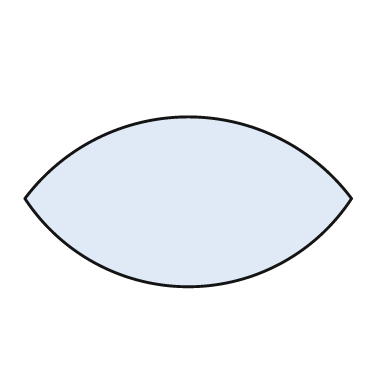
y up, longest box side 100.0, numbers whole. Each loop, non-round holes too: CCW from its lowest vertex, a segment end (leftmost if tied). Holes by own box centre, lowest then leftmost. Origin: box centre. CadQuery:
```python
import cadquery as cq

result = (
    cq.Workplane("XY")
    .moveTo(-50.0, 1.0)
    .threePointArc((0.0, -26.0), (50.0, 1.0))
    .threePointArc((0.0, 26.0), (-50.0, 1.0))
    .close()
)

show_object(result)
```